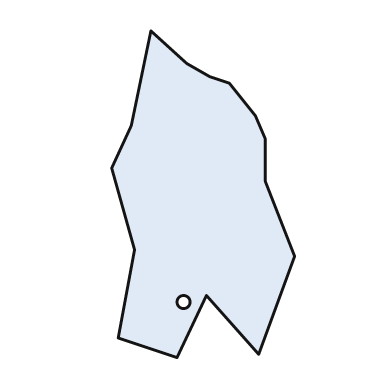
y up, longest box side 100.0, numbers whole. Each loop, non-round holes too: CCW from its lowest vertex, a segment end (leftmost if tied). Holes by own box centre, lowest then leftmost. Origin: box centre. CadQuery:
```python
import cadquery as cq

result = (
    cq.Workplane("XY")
    .moveTo(-8.0, -50.0)
    .lineTo(1.0, -31.0)
    .lineTo(17.0, -49.0)
    .lineTo(28.0, -19.0)
    .lineTo(19.0, 4.0)
    .lineTo(19.0, 17.0)
    .lineTo(16.0, 24.0)
    .lineTo(8.0, 34.0)
    .lineTo(2.0, 36.0)
    .lineTo(-5.0, 40.0)
    .lineTo(-16.0, 50.0)
    .lineTo(-22.0, 21.0)
    .lineTo(-28.0, 8.0)
    .lineTo(-21.0, -17.0)
    .lineTo(-26.0, -44.0)
    .close()
    .moveTo(-6.0, -33.0)
    .circle(2.0)
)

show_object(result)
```